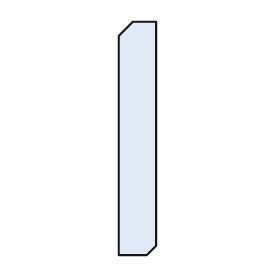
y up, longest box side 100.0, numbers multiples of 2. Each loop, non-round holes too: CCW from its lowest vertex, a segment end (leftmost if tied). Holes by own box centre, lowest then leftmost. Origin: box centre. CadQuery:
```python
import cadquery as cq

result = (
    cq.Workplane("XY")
    .moveTo(-8.0, -50.0)
    .lineTo(4.0, -50.0)
    .lineTo(8.0, -46.0)
    .lineTo(8.0, 50.0)
    .lineTo(-2.0, 50.0)
    .lineTo(-8.0, 44.0)
    .close()
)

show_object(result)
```